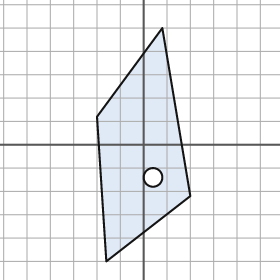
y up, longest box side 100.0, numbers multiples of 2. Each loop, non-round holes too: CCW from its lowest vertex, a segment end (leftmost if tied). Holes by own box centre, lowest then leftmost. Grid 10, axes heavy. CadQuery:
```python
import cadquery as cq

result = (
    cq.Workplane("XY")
    .moveTo(-16.0, -50.0)
    .lineTo(20.0, -22.0)
    .lineTo(8.0, 50.0)
    .lineTo(-20.0, 12.0)
    .close()
    .moveTo(4.0, -14.0)
    .circle(4.0)
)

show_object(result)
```